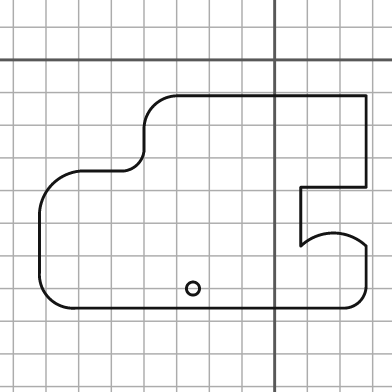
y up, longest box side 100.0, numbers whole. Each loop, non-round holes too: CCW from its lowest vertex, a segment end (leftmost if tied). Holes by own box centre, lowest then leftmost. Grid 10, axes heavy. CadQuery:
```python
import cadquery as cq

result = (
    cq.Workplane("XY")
    .moveTo(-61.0, -76.0)
    .lineTo(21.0, -76.0)
    .threePointArc((26.0, -74.0), (28.0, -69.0))
    .lineTo(28.0, -57.0)
    .threePointArc((18.0, -53.0), (8.0, -57.0))
    .lineTo(8.0, -39.0)
    .lineTo(28.0, -39.0)
    .lineTo(28.0, -11.0)
    .lineTo(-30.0, -11.0)
    .threePointArc((-37.0, -14.0), (-40.0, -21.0))
    .lineTo(-40.0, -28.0)
    .threePointArc((-42.0, -32.0), (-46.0, -34.0))
    .lineTo(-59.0, -34.0)
    .threePointArc((-68.0, -38.0), (-72.0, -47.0))
    .lineTo(-72.0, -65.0)
    .threePointArc((-69.0, -73.0), (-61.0, -76.0))
    .close()
    .moveTo(-25.0, -70.0)
    .circle(2.0)
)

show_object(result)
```